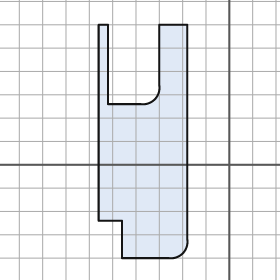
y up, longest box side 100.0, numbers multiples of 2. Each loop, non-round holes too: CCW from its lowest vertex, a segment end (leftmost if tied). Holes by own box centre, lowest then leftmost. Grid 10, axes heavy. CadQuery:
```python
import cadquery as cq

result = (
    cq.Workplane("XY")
    .moveTo(-46.0, -40.0)
    .lineTo(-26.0, -40.0)
    .threePointArc((-20.0, -38.0), (-18.0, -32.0))
    .lineTo(-18.0, 60.0)
    .lineTo(-30.0, 60.0)
    .lineTo(-30.0, 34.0)
    .threePointArc((-32.0, 28.0), (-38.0, 26.0))
    .lineTo(-52.0, 26.0)
    .lineTo(-52.0, 60.0)
    .lineTo(-56.0, 60.0)
    .lineTo(-56.0, -24.0)
    .lineTo(-46.0, -24.0)
    .close()
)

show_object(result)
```